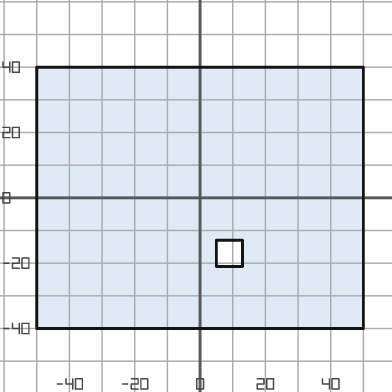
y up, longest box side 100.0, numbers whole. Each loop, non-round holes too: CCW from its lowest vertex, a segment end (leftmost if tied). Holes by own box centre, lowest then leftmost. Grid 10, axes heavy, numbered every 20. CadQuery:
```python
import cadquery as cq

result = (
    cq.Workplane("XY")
    .moveTo(-50.0, -40.0)
    .lineTo(50.0, -40.0)
    .lineTo(50.0, 40.0)
    .lineTo(-50.0, 40.0)
    .close()
    .moveTo(5.0, -21.0)
    .lineTo(13.0, -21.0)
    .lineTo(13.0, -13.0)
    .lineTo(5.0, -13.0)
    .close()
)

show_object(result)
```